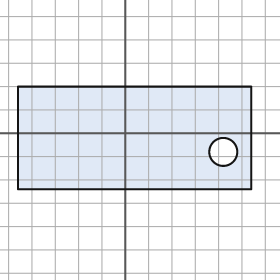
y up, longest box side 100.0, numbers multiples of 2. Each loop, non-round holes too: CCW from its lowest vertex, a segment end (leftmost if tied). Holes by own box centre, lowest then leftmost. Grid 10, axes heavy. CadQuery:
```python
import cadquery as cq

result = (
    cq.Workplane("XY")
    .moveTo(-46.0, -24.0)
    .lineTo(54.0, -24.0)
    .lineTo(54.0, 20.0)
    .lineTo(-46.0, 20.0)
    .close()
    .moveTo(42.0, -8.0)
    .circle(6.0)
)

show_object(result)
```